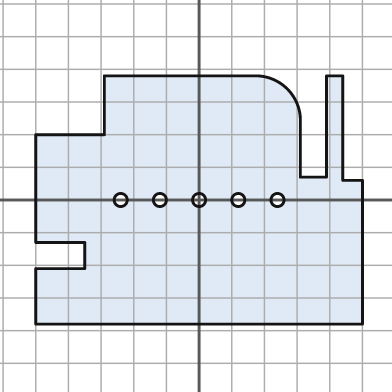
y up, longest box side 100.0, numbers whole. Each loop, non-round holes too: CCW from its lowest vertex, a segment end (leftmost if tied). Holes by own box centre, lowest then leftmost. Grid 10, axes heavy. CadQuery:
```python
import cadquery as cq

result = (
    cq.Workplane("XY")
    .moveTo(-50.0, -38.0)
    .lineTo(50.0, -38.0)
    .lineTo(50.0, 6.0)
    .lineTo(44.0, 6.0)
    .lineTo(44.0, 38.0)
    .lineTo(39.0, 38.0)
    .lineTo(39.0, 7.0)
    .lineTo(31.0, 7.0)
    .lineTo(31.0, 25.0)
    .threePointArc((27.0, 34.0), (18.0, 38.0))
    .lineTo(-29.0, 38.0)
    .lineTo(-29.0, 20.0)
    .lineTo(-50.0, 20.0)
    .lineTo(-50.0, -13.0)
    .lineTo(-35.0, -13.0)
    .lineTo(-35.0, -21.0)
    .lineTo(-50.0, -21.0)
    .close()
    .moveTo(-24.0, 0.0)
    .circle(2.0)
    .moveTo(-12.0, 0.0)
    .circle(2.0)
    .moveTo(0.0, 0.0)
    .circle(2.0)
    .moveTo(12.0, 0.0)
    .circle(2.0)
    .moveTo(24.0, 0.0)
    .circle(2.0)
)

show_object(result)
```